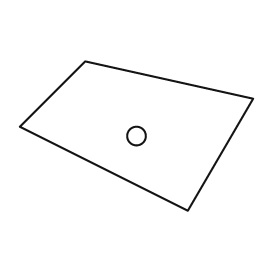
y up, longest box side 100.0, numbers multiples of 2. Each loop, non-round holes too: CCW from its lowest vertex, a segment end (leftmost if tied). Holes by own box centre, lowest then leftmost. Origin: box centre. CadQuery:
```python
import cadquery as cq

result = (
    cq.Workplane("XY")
    .moveTo(22.0, -32.0)
    .lineTo(50.0, 16.0)
    .lineTo(-22.0, 32.0)
    .lineTo(-50.0, 4.0)
    .close()
    .moveTo(0.0, 0.0)
    .circle(4.0)
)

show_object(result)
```